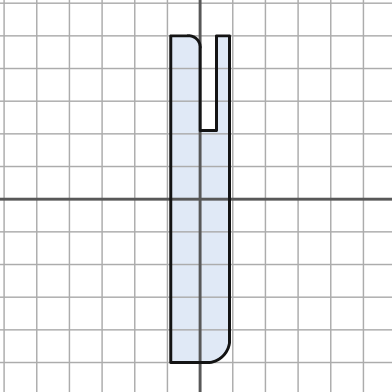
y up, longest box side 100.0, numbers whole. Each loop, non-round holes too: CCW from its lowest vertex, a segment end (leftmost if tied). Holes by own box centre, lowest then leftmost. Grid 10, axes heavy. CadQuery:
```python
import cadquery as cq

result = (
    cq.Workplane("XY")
    .moveTo(-9.0, -50.0)
    .lineTo(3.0, -50.0)
    .threePointArc((7.0, -48.0), (9.0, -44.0))
    .lineTo(9.0, 50.0)
    .lineTo(5.0, 50.0)
    .lineTo(5.0, 21.0)
    .lineTo(0.0, 21.0)
    .lineTo(0.0, 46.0)
    .threePointArc((-1.0, 49.0), (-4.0, 50.0))
    .lineTo(-9.0, 50.0)
    .close()
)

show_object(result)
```